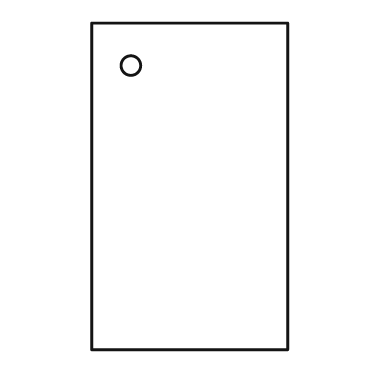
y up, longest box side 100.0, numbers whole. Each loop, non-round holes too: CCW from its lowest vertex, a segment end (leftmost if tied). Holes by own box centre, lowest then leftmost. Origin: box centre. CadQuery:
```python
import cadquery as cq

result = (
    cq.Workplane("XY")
    .moveTo(-30.0, -50.0)
    .lineTo(30.0, -50.0)
    .lineTo(30.0, 50.0)
    .lineTo(-30.0, 50.0)
    .close()
    .moveTo(-18.0, 37.0)
    .circle(3.0)
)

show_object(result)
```